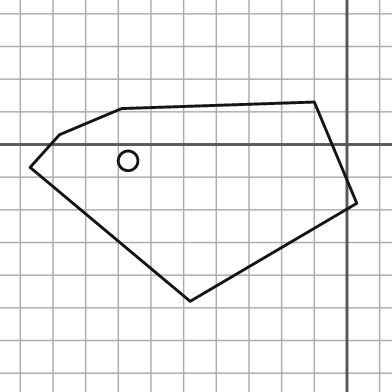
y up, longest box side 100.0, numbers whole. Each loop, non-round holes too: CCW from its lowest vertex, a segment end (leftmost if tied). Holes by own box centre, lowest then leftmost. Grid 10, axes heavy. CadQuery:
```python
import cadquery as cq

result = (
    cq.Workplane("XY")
    .moveTo(-48.0, -48.0)
    .lineTo(3.0, -18.0)
    .lineTo(-10.0, 13.0)
    .lineTo(-69.0, 11.0)
    .lineTo(-88.0, 3.0)
    .lineTo(-97.0, -7.0)
    .close()
    .moveTo(-67.0, -5.0)
    .circle(3.0)
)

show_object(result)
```